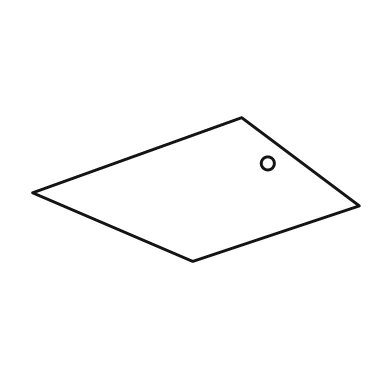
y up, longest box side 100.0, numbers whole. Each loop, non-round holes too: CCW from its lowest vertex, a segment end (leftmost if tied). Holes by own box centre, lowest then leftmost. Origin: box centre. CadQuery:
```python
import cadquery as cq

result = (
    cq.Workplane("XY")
    .moveTo(-1.0, -22.0)
    .lineTo(50.0, -5.0)
    .lineTo(14.0, 22.0)
    .lineTo(-50.0, -1.0)
    .close()
    .moveTo(22.0, 8.0)
    .circle(2.0)
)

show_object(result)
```